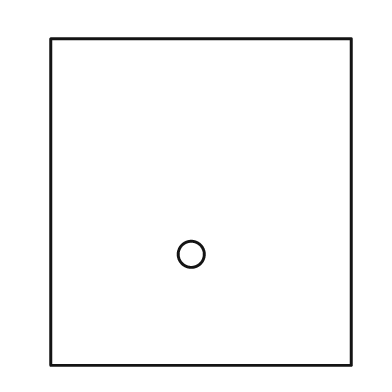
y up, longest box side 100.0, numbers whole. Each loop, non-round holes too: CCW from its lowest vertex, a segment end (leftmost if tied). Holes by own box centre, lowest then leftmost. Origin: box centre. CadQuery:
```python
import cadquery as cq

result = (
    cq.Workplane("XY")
    .moveTo(-46.0, -50.0)
    .lineTo(46.0, -50.0)
    .lineTo(46.0, 50.0)
    .lineTo(-46.0, 50.0)
    .close()
    .moveTo(-3.0, -16.0)
    .circle(4.0)
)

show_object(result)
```